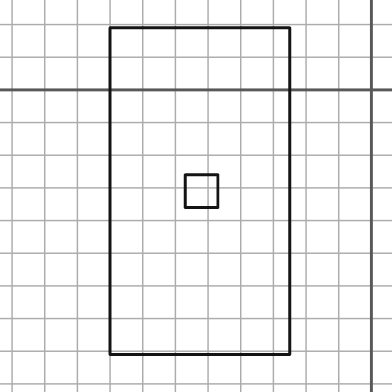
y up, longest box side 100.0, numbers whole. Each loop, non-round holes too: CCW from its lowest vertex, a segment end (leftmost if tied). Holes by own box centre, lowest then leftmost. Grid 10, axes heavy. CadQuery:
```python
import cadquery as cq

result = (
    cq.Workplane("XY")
    .moveTo(-80.0, -81.0)
    .lineTo(-25.0, -81.0)
    .lineTo(-25.0, 19.0)
    .lineTo(-80.0, 19.0)
    .close()
    .moveTo(-57.0, -36.0)
    .lineTo(-47.0, -36.0)
    .lineTo(-47.0, -26.0)
    .lineTo(-57.0, -26.0)
    .close()
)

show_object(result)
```